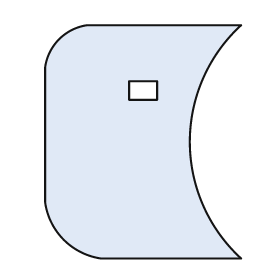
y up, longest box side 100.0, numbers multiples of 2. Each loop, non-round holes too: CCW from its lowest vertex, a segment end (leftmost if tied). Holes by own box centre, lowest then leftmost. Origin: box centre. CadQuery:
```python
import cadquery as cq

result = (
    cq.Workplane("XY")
    .moveTo(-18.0, -50.0)
    .lineTo(42.0, -50.0)
    .threePointArc((20.0, 0.0), (42.0, 50.0))
    .lineTo(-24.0, 50.0)
    .threePointArc((-36.0, 44.0), (-42.0, 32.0))
    .lineTo(-42.0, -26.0)
    .threePointArc((-34.0, -42.0), (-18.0, -50.0))
    .close()
    .moveTo(-6.0, 18.0)
    .lineTo(6.0, 18.0)
    .lineTo(6.0, 26.0)
    .lineTo(-6.0, 26.0)
    .close()
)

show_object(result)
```